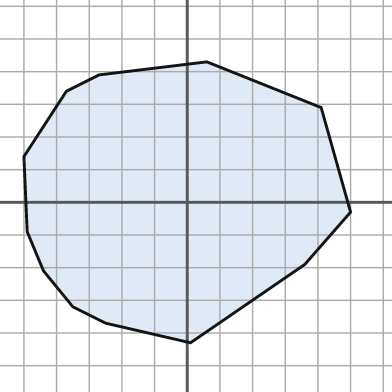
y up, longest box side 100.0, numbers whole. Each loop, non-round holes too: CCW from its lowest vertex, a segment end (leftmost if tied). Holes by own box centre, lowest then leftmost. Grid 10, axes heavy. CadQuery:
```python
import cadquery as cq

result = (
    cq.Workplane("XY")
    .moveTo(1.0, -43.0)
    .lineTo(36.0, -19.0)
    .lineTo(50.0, -3.0)
    .lineTo(41.0, 29.0)
    .lineTo(6.0, 43.0)
    .lineTo(-27.0, 39.0)
    .lineTo(-37.0, 34.0)
    .lineTo(-50.0, 14.0)
    .lineTo(-49.0, -9.0)
    .lineTo(-44.0, -21.0)
    .lineTo(-35.0, -32.0)
    .lineTo(-25.0, -37.0)
    .close()
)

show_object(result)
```